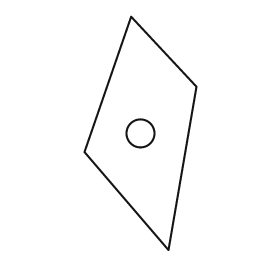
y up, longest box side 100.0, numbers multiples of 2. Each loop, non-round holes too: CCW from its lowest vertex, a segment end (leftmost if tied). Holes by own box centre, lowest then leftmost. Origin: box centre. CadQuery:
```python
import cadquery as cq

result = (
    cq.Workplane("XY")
    .moveTo(12.0, -50.0)
    .lineTo(24.0, 20.0)
    .lineTo(-4.0, 50.0)
    .lineTo(-24.0, -8.0)
    .close()
    .moveTo(0.0, 0.0)
    .circle(6.0)
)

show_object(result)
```